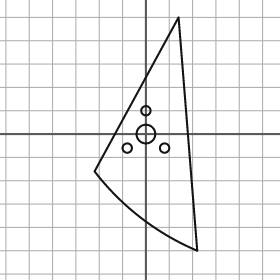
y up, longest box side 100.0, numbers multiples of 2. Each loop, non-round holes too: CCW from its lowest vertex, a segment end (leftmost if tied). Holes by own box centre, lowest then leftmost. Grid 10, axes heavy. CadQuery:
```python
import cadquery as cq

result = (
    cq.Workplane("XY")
    .moveTo(22.0, -50.0)
    .lineTo(14.0, 50.0)
    .lineTo(-22.0, -16.0)
    .threePointArc((-2.0, -36.0), (22.0, -50.0))
    .close()
    .moveTo(-8.0, -6.0)
    .circle(2.0)
    .moveTo(8.0, -6.0)
    .circle(2.0)
    .moveTo(0.0, 0.0)
    .circle(4.0)
    .moveTo(0.0, 10.0)
    .circle(2.0)
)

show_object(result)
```